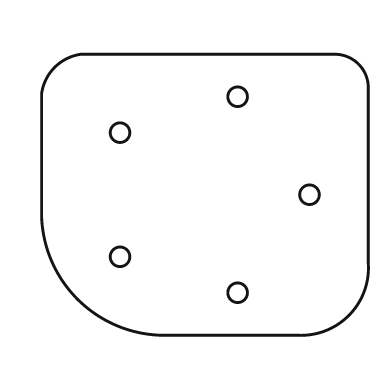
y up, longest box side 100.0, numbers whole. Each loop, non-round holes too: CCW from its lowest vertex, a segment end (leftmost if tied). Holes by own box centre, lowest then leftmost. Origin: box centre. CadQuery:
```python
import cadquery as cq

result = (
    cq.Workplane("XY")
    .moveTo(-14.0, -43.0)
    .lineTo(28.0, -43.0)
    .threePointArc((44.0, -37.0), (50.0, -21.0))
    .lineTo(50.0, 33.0)
    .threePointArc((47.0, 40.0), (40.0, 43.0))
    .lineTo(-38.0, 43.0)
    .threePointArc((-46.0, 39.0), (-50.0, 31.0))
    .lineTo(-50.0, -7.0)
    .threePointArc((-39.0, -32.0), (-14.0, -43.0))
    .close()
    .moveTo(10.0, -30.0)
    .circle(3.0)
    .moveTo(-26.0, -19.0)
    .circle(3.0)
    .moveTo(32.0, 0.0)
    .circle(3.0)
    .moveTo(-26.0, 19.0)
    .circle(3.0)
    .moveTo(10.0, 30.0)
    .circle(3.0)
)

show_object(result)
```